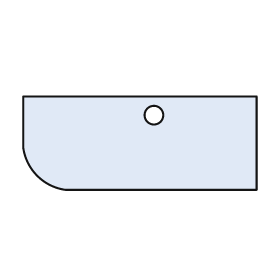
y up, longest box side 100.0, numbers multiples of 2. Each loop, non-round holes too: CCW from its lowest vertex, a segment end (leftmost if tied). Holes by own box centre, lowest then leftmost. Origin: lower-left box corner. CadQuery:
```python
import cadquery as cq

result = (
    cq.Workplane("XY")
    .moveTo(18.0, 0.0)
    .lineTo(100.0, 0.0)
    .lineTo(100.0, 40.0)
    .lineTo(0.0, 40.0)
    .lineTo(0.0, 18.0)
    .threePointArc((6.0, 6.0), (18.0, 0.0))
    .close()
    .moveTo(56.0, 32.0)
    .circle(4.0)
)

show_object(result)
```